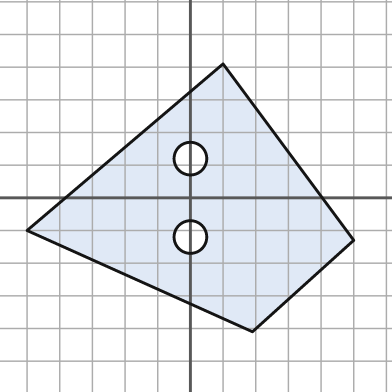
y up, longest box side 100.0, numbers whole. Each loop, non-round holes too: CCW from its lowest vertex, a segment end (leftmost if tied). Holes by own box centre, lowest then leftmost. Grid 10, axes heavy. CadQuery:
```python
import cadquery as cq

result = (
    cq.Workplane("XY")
    .moveTo(19.0, -41.0)
    .lineTo(50.0, -13.0)
    .lineTo(10.0, 41.0)
    .lineTo(-50.0, -10.0)
    .close()
    .moveTo(0.0, -12.0)
    .circle(5.0)
    .moveTo(0.0, 12.0)
    .circle(5.0)
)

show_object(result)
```